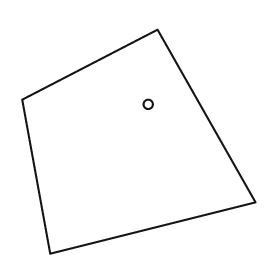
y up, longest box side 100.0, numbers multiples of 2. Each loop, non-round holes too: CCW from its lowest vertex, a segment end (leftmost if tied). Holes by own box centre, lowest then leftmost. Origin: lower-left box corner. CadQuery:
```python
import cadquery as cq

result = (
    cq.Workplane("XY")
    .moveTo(12.0, 0.0)
    .lineTo(100.0, 22.0)
    .lineTo(58.0, 96.0)
    .lineTo(0.0, 66.0)
    .close()
    .moveTo(54.0, 64.0)
    .circle(2.0)
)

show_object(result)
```